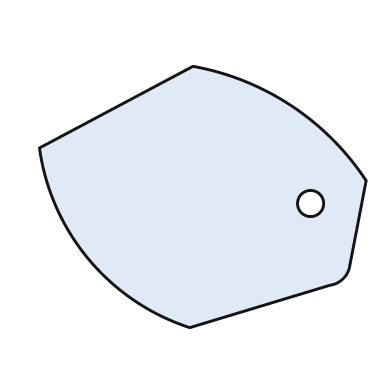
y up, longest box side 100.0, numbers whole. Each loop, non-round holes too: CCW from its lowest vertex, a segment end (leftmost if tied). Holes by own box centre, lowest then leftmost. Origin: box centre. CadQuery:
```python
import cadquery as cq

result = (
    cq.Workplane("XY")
    .moveTo(-4.0, -40.0)
    .lineTo(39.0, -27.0)
    .threePointArc((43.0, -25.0), (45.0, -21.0))
    .lineTo(50.0, 5.0)
    .threePointArc((27.0, 28.0), (-3.0, 40.0))
    .lineTo(-50.0, 15.0)
    .threePointArc((-35.0, -19.0), (-4.0, -40.0))
    .close()
    .moveTo(33.0, -2.0)
    .circle(4.0)
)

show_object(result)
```